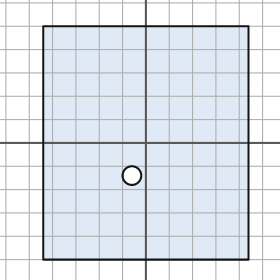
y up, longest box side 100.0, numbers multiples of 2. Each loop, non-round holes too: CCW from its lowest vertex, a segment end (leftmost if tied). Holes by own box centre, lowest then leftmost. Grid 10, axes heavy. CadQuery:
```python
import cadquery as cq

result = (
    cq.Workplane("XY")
    .moveTo(-44.0, -50.0)
    .lineTo(44.0, -50.0)
    .lineTo(44.0, 50.0)
    .lineTo(-44.0, 50.0)
    .close()
    .moveTo(-6.0, -14.0)
    .circle(4.0)
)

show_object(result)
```